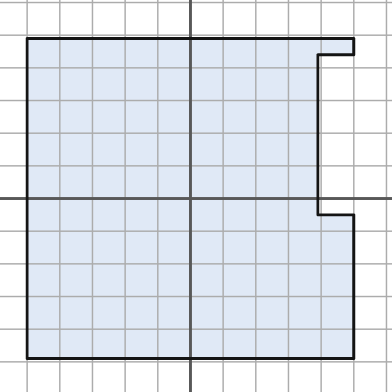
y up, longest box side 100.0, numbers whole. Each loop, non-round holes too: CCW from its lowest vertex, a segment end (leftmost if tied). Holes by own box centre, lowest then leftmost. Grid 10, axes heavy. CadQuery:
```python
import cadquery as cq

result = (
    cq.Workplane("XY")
    .moveTo(-50.0, -49.0)
    .lineTo(50.0, -49.0)
    .lineTo(50.0, -5.0)
    .lineTo(39.0, -5.0)
    .lineTo(39.0, 44.0)
    .lineTo(50.0, 44.0)
    .lineTo(50.0, 49.0)
    .lineTo(-50.0, 49.0)
    .close()
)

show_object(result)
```